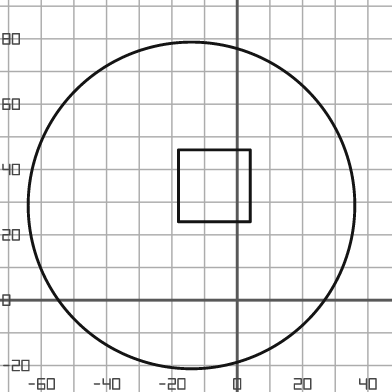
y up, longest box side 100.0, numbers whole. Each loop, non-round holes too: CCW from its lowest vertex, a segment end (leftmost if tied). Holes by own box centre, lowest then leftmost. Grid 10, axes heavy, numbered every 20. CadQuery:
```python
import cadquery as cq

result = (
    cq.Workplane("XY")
    .moveTo(-14.0, 29.0)
    .circle(50.0)
    .moveTo(-18.0, 24.0)
    .lineTo(4.0, 24.0)
    .lineTo(4.0, 46.0)
    .lineTo(-18.0, 46.0)
    .close()
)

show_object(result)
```